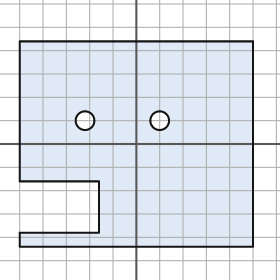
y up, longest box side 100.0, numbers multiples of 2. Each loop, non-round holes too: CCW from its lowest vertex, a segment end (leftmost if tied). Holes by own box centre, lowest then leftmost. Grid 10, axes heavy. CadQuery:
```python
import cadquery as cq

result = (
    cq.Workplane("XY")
    .moveTo(-50.0, -44.0)
    .lineTo(50.0, -44.0)
    .lineTo(50.0, 44.0)
    .lineTo(-50.0, 44.0)
    .lineTo(-50.0, -16.0)
    .lineTo(-16.0, -16.0)
    .lineTo(-16.0, -38.0)
    .lineTo(-50.0, -38.0)
    .close()
    .moveTo(-22.0, 10.0)
    .circle(4.0)
    .moveTo(10.0, 10.0)
    .circle(4.0)
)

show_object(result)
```